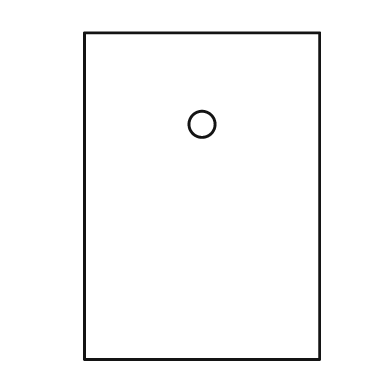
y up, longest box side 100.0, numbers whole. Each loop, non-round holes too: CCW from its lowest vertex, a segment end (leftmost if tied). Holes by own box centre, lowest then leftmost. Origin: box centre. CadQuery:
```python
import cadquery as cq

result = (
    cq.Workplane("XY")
    .moveTo(-36.0, -50.0)
    .lineTo(36.0, -50.0)
    .lineTo(36.0, 50.0)
    .lineTo(-36.0, 50.0)
    .close()
    .moveTo(0.0, 22.0)
    .circle(4.0)
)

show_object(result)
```